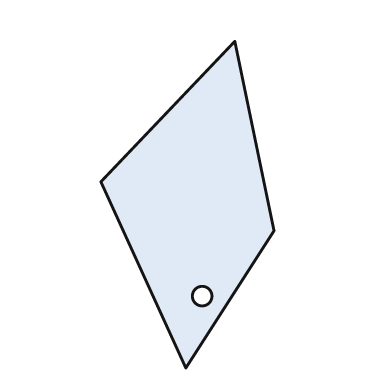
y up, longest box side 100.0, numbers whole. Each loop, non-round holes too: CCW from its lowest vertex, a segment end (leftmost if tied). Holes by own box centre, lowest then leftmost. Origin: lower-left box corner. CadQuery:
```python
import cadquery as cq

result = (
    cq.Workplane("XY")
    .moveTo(26.0, 0.0)
    .lineTo(53.0, 42.0)
    .lineTo(41.0, 100.0)
    .lineTo(0.0, 57.0)
    .close()
    .moveTo(31.0, 22.0)
    .circle(3.0)
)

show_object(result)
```